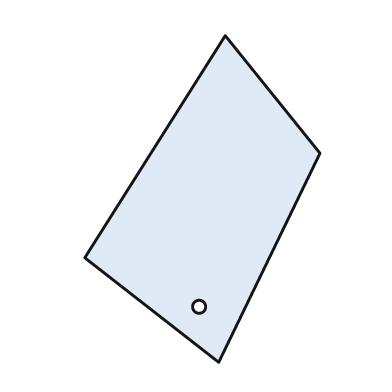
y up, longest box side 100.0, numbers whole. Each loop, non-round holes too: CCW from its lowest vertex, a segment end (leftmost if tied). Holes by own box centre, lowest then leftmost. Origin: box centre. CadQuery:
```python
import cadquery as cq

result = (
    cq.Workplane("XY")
    .moveTo(5.0, -50.0)
    .lineTo(36.0, 14.0)
    .lineTo(7.0, 50.0)
    .lineTo(-36.0, -18.0)
    .close()
    .moveTo(-1.0, -33.0)
    .circle(2.0)
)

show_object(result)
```